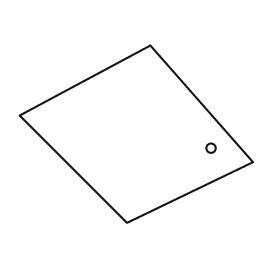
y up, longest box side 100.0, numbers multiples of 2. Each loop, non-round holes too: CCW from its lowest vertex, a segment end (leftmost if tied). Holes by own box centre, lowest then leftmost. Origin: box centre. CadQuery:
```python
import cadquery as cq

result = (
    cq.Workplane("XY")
    .moveTo(-4.0, -38.0)
    .lineTo(50.0, -12.0)
    .lineTo(6.0, 38.0)
    .lineTo(-50.0, 8.0)
    .close()
    .moveTo(32.0, -6.0)
    .circle(2.0)
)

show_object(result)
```